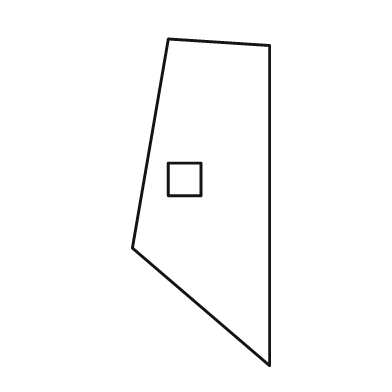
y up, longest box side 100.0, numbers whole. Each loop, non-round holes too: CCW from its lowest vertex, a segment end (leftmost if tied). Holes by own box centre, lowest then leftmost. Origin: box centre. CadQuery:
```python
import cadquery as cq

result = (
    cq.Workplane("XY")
    .moveTo(21.0, -50.0)
    .lineTo(21.0, 48.0)
    .lineTo(-10.0, 50.0)
    .lineTo(-21.0, -14.0)
    .close()
    .moveTo(-10.0, 2.0)
    .lineTo(0.0, 2.0)
    .lineTo(0.0, 12.0)
    .lineTo(-10.0, 12.0)
    .close()
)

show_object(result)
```